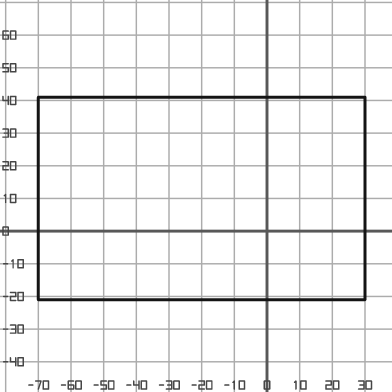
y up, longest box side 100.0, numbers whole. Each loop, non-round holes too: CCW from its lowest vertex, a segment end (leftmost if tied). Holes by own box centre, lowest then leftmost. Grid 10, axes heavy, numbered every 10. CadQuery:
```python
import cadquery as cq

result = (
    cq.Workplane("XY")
    .moveTo(-70.0, -21.0)
    .lineTo(30.0, -21.0)
    .lineTo(30.0, 41.0)
    .lineTo(-70.0, 41.0)
    .close()
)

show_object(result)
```